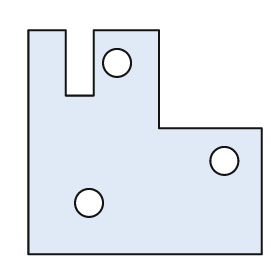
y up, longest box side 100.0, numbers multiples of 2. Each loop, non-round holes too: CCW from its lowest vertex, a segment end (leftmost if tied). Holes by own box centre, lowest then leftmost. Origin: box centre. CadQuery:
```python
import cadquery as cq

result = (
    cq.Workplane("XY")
    .moveTo(-50.0, -48.0)
    .lineTo(50.0, -48.0)
    .lineTo(50.0, 6.0)
    .lineTo(6.0, 6.0)
    .lineTo(6.0, 48.0)
    .lineTo(-22.0, 48.0)
    .lineTo(-22.0, 20.0)
    .lineTo(-34.0, 20.0)
    .lineTo(-34.0, 48.0)
    .lineTo(-50.0, 48.0)
    .close()
    .moveTo(-24.0, -26.0)
    .circle(6.0)
    .moveTo(34.0, -8.0)
    .circle(6.0)
    .moveTo(-12.0, 34.0)
    .circle(6.0)
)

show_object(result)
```